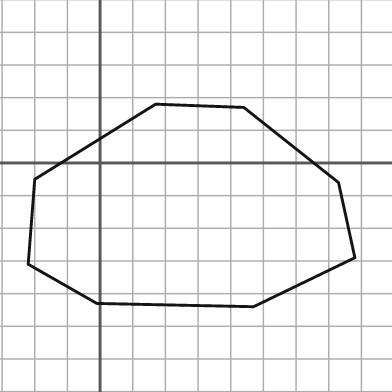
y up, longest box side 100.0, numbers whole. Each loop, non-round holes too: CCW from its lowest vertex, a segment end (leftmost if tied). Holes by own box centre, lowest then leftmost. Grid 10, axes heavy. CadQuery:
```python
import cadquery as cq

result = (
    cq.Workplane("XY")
    .moveTo(47.0, -44.0)
    .lineTo(78.0, -29.0)
    .lineTo(73.0, -6.0)
    .lineTo(44.0, 17.0)
    .lineTo(17.0, 18.0)
    .lineTo(-20.0, -5.0)
    .lineTo(-22.0, -31.0)
    .lineTo(-1.0, -43.0)
    .close()
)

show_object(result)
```